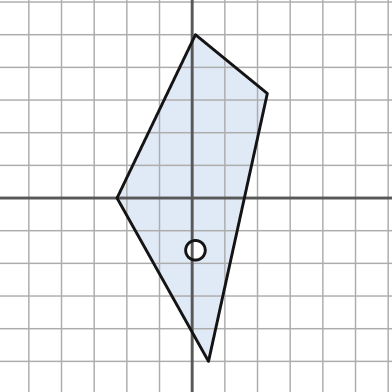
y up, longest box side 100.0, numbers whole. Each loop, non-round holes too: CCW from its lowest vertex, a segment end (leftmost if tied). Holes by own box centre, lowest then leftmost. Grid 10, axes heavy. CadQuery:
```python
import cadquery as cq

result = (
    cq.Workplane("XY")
    .moveTo(5.0, -50.0)
    .lineTo(23.0, 32.0)
    .lineTo(1.0, 50.0)
    .lineTo(-23.0, 0.0)
    .close()
    .moveTo(1.0, -16.0)
    .circle(3.0)
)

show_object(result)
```